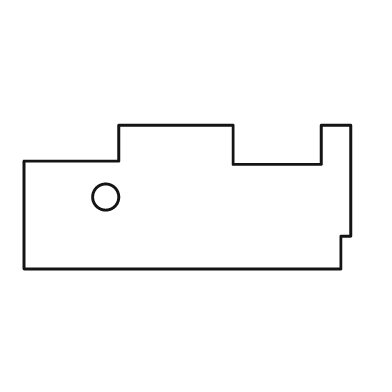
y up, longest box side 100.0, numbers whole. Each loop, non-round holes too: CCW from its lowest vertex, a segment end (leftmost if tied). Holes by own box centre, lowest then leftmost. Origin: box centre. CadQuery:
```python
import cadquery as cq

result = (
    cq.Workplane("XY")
    .moveTo(-50.0, -22.0)
    .lineTo(47.0, -22.0)
    .lineTo(47.0, -12.0)
    .lineTo(50.0, -12.0)
    .lineTo(50.0, 22.0)
    .lineTo(41.0, 22.0)
    .lineTo(41.0, 10.0)
    .lineTo(14.0, 10.0)
    .lineTo(14.0, 22.0)
    .lineTo(-21.0, 22.0)
    .lineTo(-21.0, 11.0)
    .lineTo(-50.0, 11.0)
    .close()
    .moveTo(-25.0, 0.0)
    .circle(4.0)
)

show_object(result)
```